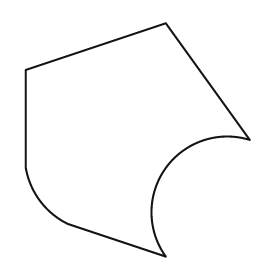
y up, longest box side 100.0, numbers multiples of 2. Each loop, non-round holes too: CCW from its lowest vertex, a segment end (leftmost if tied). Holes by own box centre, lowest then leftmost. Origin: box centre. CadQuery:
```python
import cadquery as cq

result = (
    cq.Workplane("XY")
    .moveTo(12.0, -50.0)
    .threePointArc((12.0, -12.0), (48.0, 0.0))
    .lineTo(12.0, 50.0)
    .lineTo(-48.0, 30.0)
    .lineTo(-48.0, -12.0)
    .threePointArc((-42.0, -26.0), (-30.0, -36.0))
    .close()
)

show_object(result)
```